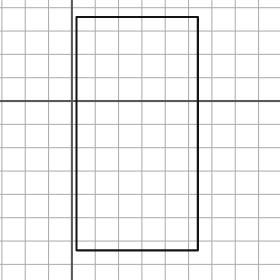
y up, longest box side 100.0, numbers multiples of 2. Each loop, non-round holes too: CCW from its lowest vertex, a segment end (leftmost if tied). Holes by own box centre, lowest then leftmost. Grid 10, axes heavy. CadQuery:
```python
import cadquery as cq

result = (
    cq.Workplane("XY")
    .moveTo(2.0, -64.0)
    .lineTo(54.0, -64.0)
    .lineTo(54.0, 36.0)
    .lineTo(2.0, 36.0)
    .close()
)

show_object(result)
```